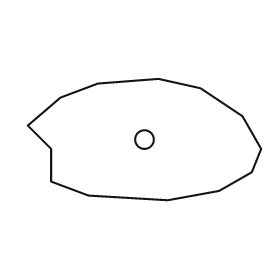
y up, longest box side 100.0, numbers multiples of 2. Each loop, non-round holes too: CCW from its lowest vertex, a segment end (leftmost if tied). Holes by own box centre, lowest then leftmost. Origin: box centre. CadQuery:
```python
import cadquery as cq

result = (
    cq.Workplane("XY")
    .moveTo(10.0, -26.0)
    .lineTo(32.0, -22.0)
    .lineTo(46.0, -14.0)
    .lineTo(50.0, -4.0)
    .lineTo(42.0, 10.0)
    .lineTo(24.0, 22.0)
    .lineTo(6.0, 26.0)
    .lineTo(-20.0, 24.0)
    .lineTo(-36.0, 18.0)
    .lineTo(-50.0, 6.0)
    .lineTo(-40.0, -4.0)
    .lineTo(-40.0, -18.0)
    .lineTo(-24.0, -24.0)
    .close()
    .moveTo(0.0, 0.0)
    .circle(4.0)
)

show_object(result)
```